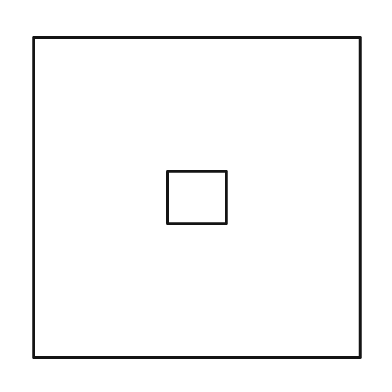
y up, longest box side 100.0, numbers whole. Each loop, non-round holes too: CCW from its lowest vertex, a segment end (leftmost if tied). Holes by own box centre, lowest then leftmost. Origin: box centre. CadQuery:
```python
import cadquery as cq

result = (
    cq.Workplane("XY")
    .moveTo(-50.0, -49.0)
    .lineTo(50.0, -49.0)
    .lineTo(50.0, 49.0)
    .lineTo(-50.0, 49.0)
    .close()
    .moveTo(-9.0, -8.0)
    .lineTo(9.0, -8.0)
    .lineTo(9.0, 8.0)
    .lineTo(-9.0, 8.0)
    .close()
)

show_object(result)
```